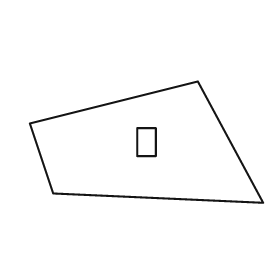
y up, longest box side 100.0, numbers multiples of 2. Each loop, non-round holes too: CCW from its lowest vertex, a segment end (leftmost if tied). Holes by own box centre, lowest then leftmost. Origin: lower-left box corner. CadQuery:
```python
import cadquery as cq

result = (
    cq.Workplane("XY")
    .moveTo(100.0, 0.0)
    .lineTo(72.0, 52.0)
    .lineTo(0.0, 34.0)
    .lineTo(10.0, 4.0)
    .close()
    .moveTo(46.0, 20.0)
    .lineTo(54.0, 20.0)
    .lineTo(54.0, 32.0)
    .lineTo(46.0, 32.0)
    .close()
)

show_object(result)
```